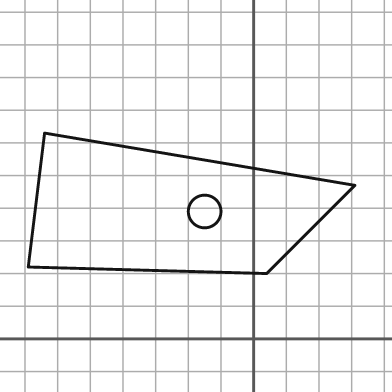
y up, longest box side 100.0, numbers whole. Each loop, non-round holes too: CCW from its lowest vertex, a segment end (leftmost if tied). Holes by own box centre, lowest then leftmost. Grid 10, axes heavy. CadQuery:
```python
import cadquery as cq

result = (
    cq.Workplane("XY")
    .moveTo(4.0, 20.0)
    .lineTo(31.0, 47.0)
    .lineTo(-64.0, 63.0)
    .lineTo(-69.0, 22.0)
    .close()
    .moveTo(-15.0, 39.0)
    .circle(5.0)
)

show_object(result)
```